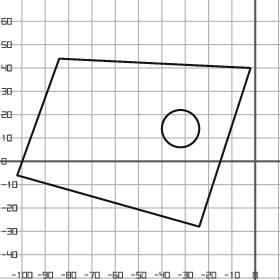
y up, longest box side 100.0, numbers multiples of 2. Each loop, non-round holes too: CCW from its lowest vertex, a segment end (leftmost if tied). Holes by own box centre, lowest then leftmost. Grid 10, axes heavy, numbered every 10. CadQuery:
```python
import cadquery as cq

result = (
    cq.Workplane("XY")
    .moveTo(-24.0, -28.0)
    .lineTo(-2.0, 40.0)
    .lineTo(-84.0, 44.0)
    .lineTo(-102.0, -6.0)
    .close()
    .moveTo(-32.0, 14.0)
    .circle(8.0)
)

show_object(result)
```